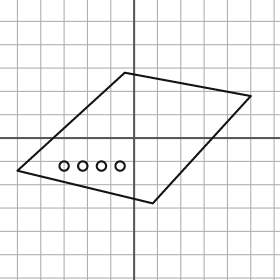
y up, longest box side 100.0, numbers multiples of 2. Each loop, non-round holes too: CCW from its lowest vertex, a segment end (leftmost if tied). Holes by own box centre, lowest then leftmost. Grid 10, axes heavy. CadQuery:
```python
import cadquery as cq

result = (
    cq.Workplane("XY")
    .moveTo(8.0, -28.0)
    .lineTo(50.0, 18.0)
    .lineTo(-4.0, 28.0)
    .lineTo(-50.0, -14.0)
    .close()
    .moveTo(-30.0, -12.0)
    .circle(2.0)
    .moveTo(-22.0, -12.0)
    .circle(2.0)
    .moveTo(-14.0, -12.0)
    .circle(2.0)
    .moveTo(-6.0, -12.0)
    .circle(2.0)
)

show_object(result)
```